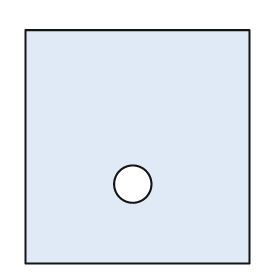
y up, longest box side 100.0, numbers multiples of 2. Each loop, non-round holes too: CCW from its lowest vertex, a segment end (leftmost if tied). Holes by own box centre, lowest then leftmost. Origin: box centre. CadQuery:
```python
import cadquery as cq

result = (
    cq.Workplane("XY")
    .moveTo(-48.0, -50.0)
    .lineTo(48.0, -50.0)
    .lineTo(48.0, 50.0)
    .lineTo(-48.0, 50.0)
    .close()
    .moveTo(-2.0, -16.0)
    .circle(8.0)
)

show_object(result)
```